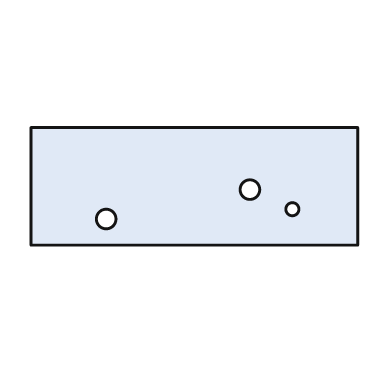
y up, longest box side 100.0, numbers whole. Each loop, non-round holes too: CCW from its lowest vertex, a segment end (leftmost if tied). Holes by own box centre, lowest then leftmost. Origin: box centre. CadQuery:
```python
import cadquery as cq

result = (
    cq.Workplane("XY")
    .moveTo(-50.0, -18.0)
    .lineTo(50.0, -18.0)
    .lineTo(50.0, 18.0)
    .lineTo(-50.0, 18.0)
    .close()
    .moveTo(-27.0, -10.0)
    .circle(3.0)
    .moveTo(30.0, -7.0)
    .circle(2.0)
    .moveTo(17.0, -1.0)
    .circle(3.0)
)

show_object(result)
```